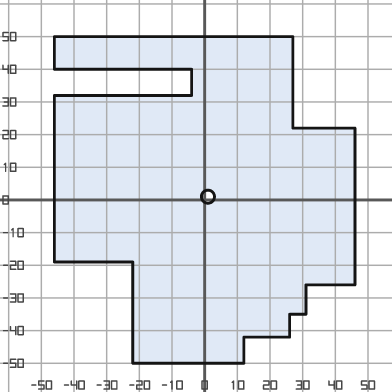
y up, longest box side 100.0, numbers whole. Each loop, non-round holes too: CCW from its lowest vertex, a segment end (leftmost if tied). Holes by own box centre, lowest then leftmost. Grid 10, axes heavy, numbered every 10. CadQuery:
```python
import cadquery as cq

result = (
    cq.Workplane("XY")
    .moveTo(-22.0, -50.0)
    .lineTo(12.0, -50.0)
    .lineTo(12.0, -42.0)
    .lineTo(26.0, -42.0)
    .lineTo(26.0, -35.0)
    .lineTo(31.0, -35.0)
    .lineTo(31.0, -26.0)
    .lineTo(46.0, -26.0)
    .lineTo(46.0, 22.0)
    .lineTo(27.0, 22.0)
    .lineTo(27.0, 50.0)
    .lineTo(-46.0, 50.0)
    .lineTo(-46.0, 40.0)
    .lineTo(-4.0, 40.0)
    .lineTo(-4.0, 32.0)
    .lineTo(-46.0, 32.0)
    .lineTo(-46.0, -19.0)
    .lineTo(-22.0, -19.0)
    .close()
    .moveTo(1.0, 1.0)
    .circle(2.0)
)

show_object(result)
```